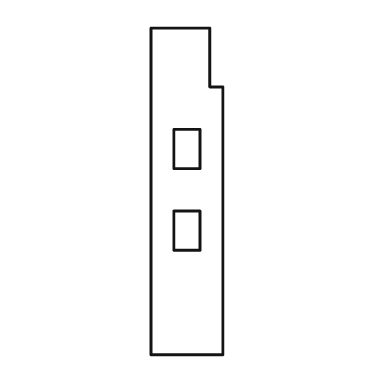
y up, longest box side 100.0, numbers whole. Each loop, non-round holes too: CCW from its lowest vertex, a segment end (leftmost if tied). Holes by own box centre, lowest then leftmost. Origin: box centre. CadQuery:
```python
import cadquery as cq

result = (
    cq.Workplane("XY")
    .moveTo(-11.0, -50.0)
    .lineTo(11.0, -50.0)
    .lineTo(11.0, 32.0)
    .lineTo(7.0, 32.0)
    .lineTo(7.0, 50.0)
    .lineTo(-11.0, 50.0)
    .close()
    .moveTo(-4.0, -18.0)
    .lineTo(4.0, -18.0)
    .lineTo(4.0, -6.0)
    .lineTo(-4.0, -6.0)
    .close()
    .moveTo(-4.0, 7.0)
    .lineTo(4.0, 7.0)
    .lineTo(4.0, 19.0)
    .lineTo(-4.0, 19.0)
    .close()
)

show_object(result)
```